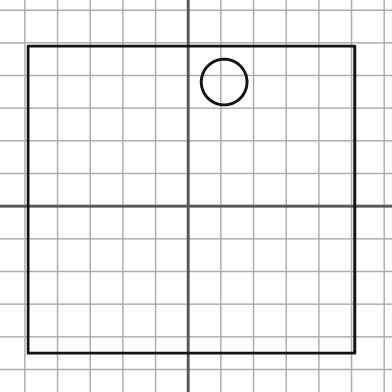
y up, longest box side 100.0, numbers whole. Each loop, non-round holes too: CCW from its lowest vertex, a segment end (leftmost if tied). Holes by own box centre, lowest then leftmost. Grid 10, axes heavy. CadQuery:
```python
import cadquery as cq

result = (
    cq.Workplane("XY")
    .moveTo(-49.0, -45.0)
    .lineTo(51.0, -45.0)
    .lineTo(51.0, 49.0)
    .lineTo(-49.0, 49.0)
    .close()
    .moveTo(11.0, 38.0)
    .circle(7.0)
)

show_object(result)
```